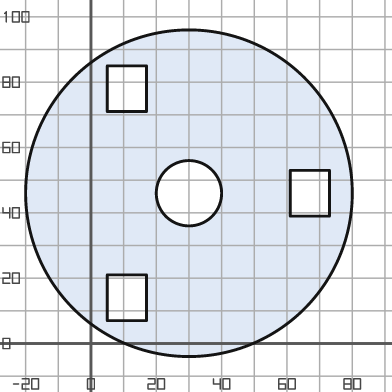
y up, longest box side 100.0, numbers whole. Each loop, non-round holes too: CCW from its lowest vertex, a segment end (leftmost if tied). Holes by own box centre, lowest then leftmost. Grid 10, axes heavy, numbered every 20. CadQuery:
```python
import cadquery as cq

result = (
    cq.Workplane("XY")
    .moveTo(30.0, 46.0)
    .circle(50.0)
    .moveTo(5.0, 7.0)
    .lineTo(17.0, 7.0)
    .lineTo(17.0, 21.0)
    .lineTo(5.0, 21.0)
    .close()
    .moveTo(30.0, 46.0)
    .circle(10.0)
    .moveTo(61.0, 39.0)
    .lineTo(73.0, 39.0)
    .lineTo(73.0, 53.0)
    .lineTo(61.0, 53.0)
    .close()
    .moveTo(5.0, 71.0)
    .lineTo(17.0, 71.0)
    .lineTo(17.0, 85.0)
    .lineTo(5.0, 85.0)
    .close()
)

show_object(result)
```